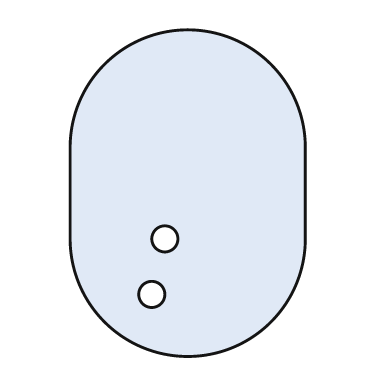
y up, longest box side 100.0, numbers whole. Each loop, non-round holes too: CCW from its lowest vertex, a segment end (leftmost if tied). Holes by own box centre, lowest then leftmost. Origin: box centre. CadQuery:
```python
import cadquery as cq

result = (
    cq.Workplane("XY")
    .moveTo(-36.0, -14.0)
    .threePointArc((0.0, -50.0), (36.0, -14.0))
    .lineTo(36.0, 14.0)
    .threePointArc((0.0, 50.0), (-36.0, 14.0))
    .close()
    .moveTo(-11.0, -31.0)
    .circle(4.0)
    .moveTo(-7.0, -14.0)
    .circle(4.0)
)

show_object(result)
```